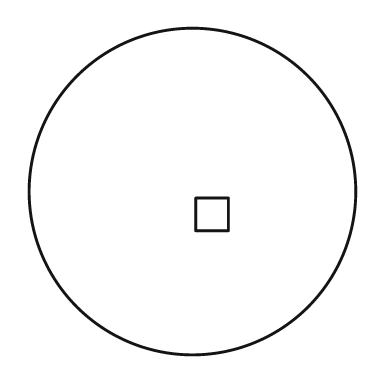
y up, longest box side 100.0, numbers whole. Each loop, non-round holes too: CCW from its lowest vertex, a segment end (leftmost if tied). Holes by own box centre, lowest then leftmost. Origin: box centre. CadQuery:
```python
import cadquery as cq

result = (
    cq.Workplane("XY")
    .moveTo(0.0, 0.0)
    .circle(50.0)
    .moveTo(1.0, -12.0)
    .lineTo(11.0, -12.0)
    .lineTo(11.0, -2.0)
    .lineTo(1.0, -2.0)
    .close()
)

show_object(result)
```